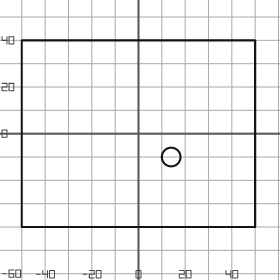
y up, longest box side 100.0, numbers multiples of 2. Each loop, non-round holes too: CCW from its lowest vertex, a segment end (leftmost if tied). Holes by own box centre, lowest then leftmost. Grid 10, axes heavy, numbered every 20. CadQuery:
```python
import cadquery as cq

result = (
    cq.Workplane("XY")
    .moveTo(-50.0, -40.0)
    .lineTo(50.0, -40.0)
    .lineTo(50.0, 40.0)
    .lineTo(-50.0, 40.0)
    .close()
    .moveTo(14.0, -10.0)
    .circle(4.0)
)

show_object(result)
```